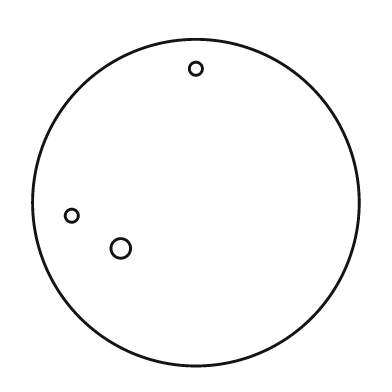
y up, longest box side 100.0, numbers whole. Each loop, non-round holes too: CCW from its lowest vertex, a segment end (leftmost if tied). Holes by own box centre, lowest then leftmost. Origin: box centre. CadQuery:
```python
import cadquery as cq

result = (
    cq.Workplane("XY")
    .moveTo(0.0, 0.0)
    .circle(50.0)
    .moveTo(-23.0, -14.0)
    .circle(3.0)
    .moveTo(-38.0, -4.0)
    .circle(2.0)
    .moveTo(0.0, 41.0)
    .circle(2.0)
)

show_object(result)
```